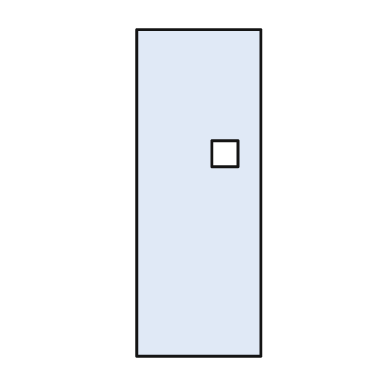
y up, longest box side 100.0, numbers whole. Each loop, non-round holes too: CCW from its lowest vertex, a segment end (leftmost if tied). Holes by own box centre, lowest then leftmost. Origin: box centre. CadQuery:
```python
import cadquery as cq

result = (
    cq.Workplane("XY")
    .moveTo(-19.0, -50.0)
    .lineTo(19.0, -50.0)
    .lineTo(19.0, 50.0)
    .lineTo(-19.0, 50.0)
    .close()
    .moveTo(4.0, 8.0)
    .lineTo(12.0, 8.0)
    .lineTo(12.0, 16.0)
    .lineTo(4.0, 16.0)
    .close()
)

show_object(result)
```